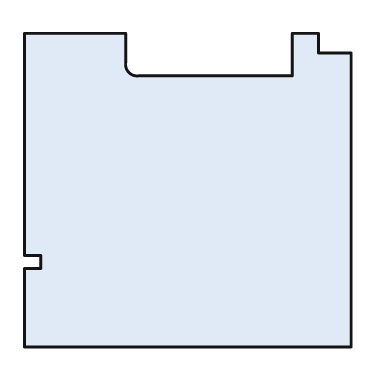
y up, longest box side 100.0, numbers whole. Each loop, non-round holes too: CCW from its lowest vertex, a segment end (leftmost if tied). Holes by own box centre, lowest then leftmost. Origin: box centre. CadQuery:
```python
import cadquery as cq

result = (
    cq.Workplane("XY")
    .moveTo(-50.0, -48.0)
    .lineTo(50.0, -48.0)
    .lineTo(50.0, 42.0)
    .lineTo(40.0, 42.0)
    .lineTo(40.0, 48.0)
    .lineTo(32.0, 48.0)
    .lineTo(32.0, 35.0)
    .lineTo(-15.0, 35.0)
    .threePointArc((-18.0, 36.0), (-19.0, 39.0))
    .lineTo(-19.0, 48.0)
    .lineTo(-50.0, 48.0)
    .lineTo(-50.0, -20.0)
    .lineTo(-45.0, -20.0)
    .lineTo(-45.0, -24.0)
    .lineTo(-50.0, -24.0)
    .close()
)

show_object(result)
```